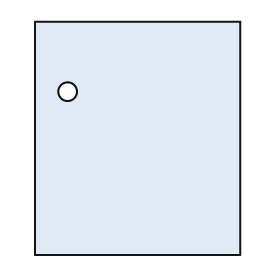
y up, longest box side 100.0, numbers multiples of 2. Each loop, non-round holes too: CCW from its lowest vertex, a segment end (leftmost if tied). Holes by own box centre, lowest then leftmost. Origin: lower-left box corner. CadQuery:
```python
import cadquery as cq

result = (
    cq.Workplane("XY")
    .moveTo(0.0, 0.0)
    .lineTo(88.0, 0.0)
    .lineTo(88.0, 100.0)
    .lineTo(0.0, 100.0)
    .close()
    .moveTo(14.0, 70.0)
    .circle(4.0)
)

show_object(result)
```